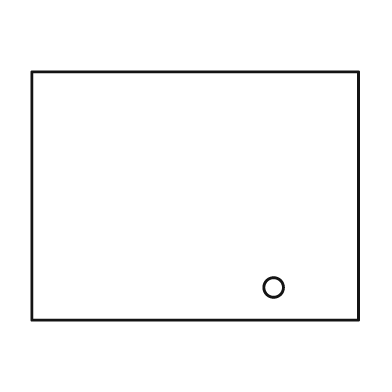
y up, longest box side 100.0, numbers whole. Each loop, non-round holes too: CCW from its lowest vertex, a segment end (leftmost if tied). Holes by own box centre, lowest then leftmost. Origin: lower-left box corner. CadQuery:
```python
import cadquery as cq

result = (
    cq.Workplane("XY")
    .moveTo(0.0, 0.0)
    .lineTo(100.0, 0.0)
    .lineTo(100.0, 76.0)
    .lineTo(0.0, 76.0)
    .close()
    .moveTo(74.0, 10.0)
    .circle(3.0)
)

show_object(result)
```